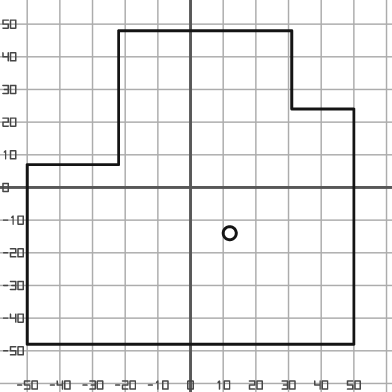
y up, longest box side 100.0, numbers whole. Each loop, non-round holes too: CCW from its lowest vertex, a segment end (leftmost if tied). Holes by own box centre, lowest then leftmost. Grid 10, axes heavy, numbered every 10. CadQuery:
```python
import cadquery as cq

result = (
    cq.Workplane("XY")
    .moveTo(-50.0, -48.0)
    .lineTo(50.0, -48.0)
    .lineTo(50.0, 24.0)
    .lineTo(31.0, 24.0)
    .lineTo(31.0, 48.0)
    .lineTo(-22.0, 48.0)
    .lineTo(-22.0, 7.0)
    .lineTo(-50.0, 7.0)
    .close()
    .moveTo(12.0, -14.0)
    .circle(2.0)
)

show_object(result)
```